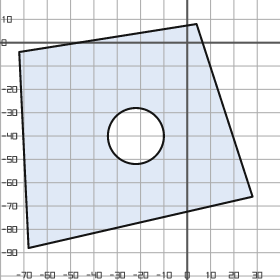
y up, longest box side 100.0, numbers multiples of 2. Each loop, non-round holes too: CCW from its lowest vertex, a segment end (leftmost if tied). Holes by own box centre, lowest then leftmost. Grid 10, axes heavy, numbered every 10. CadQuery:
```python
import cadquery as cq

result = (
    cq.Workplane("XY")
    .moveTo(-68.0, -88.0)
    .lineTo(28.0, -66.0)
    .lineTo(4.0, 8.0)
    .lineTo(-72.0, -4.0)
    .close()
    .moveTo(-22.0, -40.0)
    .circle(12.0)
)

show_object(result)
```